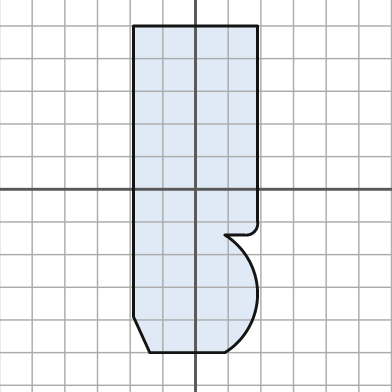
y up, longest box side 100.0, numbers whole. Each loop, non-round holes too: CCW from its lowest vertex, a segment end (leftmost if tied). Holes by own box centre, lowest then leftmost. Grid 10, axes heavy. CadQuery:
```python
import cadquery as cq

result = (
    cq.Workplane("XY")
    .moveTo(-14.0, -50.0)
    .lineTo(9.0, -50.0)
    .threePointArc((19.0, -32.0), (9.0, -14.0))
    .lineTo(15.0, -14.0)
    .threePointArc((18.0, -13.0), (19.0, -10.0))
    .lineTo(19.0, 50.0)
    .lineTo(-19.0, 50.0)
    .lineTo(-19.0, -39.0)
    .close()
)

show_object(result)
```